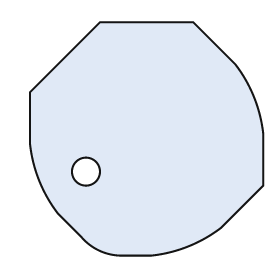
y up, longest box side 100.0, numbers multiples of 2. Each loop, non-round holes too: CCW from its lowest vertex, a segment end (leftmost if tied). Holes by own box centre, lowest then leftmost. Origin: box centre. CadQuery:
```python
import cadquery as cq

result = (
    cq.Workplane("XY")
    .moveTo(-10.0, -50.0)
    .lineTo(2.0, -50.0)
    .threePointArc((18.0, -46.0), (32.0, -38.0))
    .lineTo(50.0, -20.0)
    .lineTo(50.0, 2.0)
    .threePointArc((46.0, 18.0), (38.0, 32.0))
    .lineTo(20.0, 50.0)
    .lineTo(-20.0, 50.0)
    .lineTo(-50.0, 20.0)
    .lineTo(-50.0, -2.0)
    .threePointArc((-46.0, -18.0), (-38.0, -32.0))
    .lineTo(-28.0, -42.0)
    .threePointArc((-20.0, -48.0), (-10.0, -50.0))
    .close()
    .moveTo(-26.0, -14.0)
    .circle(6.0)
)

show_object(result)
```